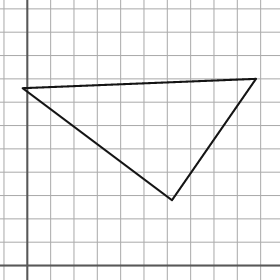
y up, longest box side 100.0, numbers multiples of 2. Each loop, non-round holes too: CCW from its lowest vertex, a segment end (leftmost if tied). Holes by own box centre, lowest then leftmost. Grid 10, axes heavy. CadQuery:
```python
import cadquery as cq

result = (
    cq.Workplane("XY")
    .moveTo(62.0, 28.0)
    .lineTo(98.0, 80.0)
    .lineTo(-2.0, 76.0)
    .close()
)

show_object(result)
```